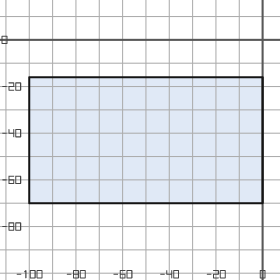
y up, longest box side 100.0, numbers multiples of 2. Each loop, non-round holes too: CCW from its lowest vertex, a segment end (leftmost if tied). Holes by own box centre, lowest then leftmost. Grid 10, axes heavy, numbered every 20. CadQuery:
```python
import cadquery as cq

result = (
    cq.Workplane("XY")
    .moveTo(-100.0, -70.0)
    .lineTo(0.0, -70.0)
    .lineTo(0.0, -16.0)
    .lineTo(-100.0, -16.0)
    .close()
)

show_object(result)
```